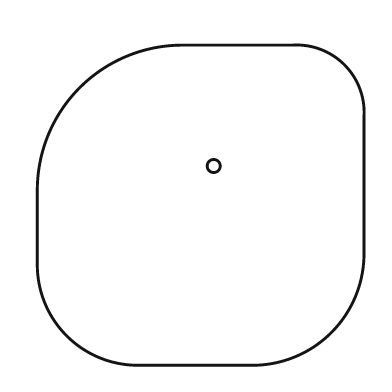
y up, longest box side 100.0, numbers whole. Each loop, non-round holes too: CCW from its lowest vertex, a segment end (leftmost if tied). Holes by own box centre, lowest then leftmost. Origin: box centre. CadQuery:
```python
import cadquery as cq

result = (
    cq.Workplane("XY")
    .moveTo(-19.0, -49.0)
    .lineTo(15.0, -49.0)
    .threePointArc((40.0, -39.0), (50.0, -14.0))
    .lineTo(50.0, 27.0)
    .threePointArc((44.0, 43.0), (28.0, 49.0))
    .lineTo(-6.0, 49.0)
    .threePointArc((-37.0, 36.0), (-50.0, 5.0))
    .lineTo(-50.0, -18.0)
    .threePointArc((-41.0, -40.0), (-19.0, -49.0))
    .close()
    .moveTo(4.0, 12.0)
    .circle(2.0)
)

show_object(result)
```